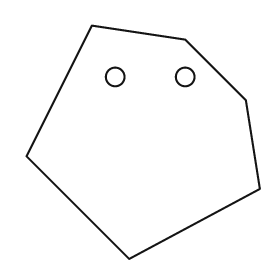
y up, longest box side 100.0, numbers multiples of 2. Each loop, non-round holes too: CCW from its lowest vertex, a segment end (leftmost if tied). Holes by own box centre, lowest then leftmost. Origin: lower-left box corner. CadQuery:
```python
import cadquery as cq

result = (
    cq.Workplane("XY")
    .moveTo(44.0, 0.0)
    .lineTo(100.0, 30.0)
    .lineTo(94.0, 68.0)
    .lineTo(68.0, 94.0)
    .lineTo(28.0, 100.0)
    .lineTo(0.0, 44.0)
    .close()
    .moveTo(38.0, 78.0)
    .circle(4.0)
    .moveTo(68.0, 78.0)
    .circle(4.0)
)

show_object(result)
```